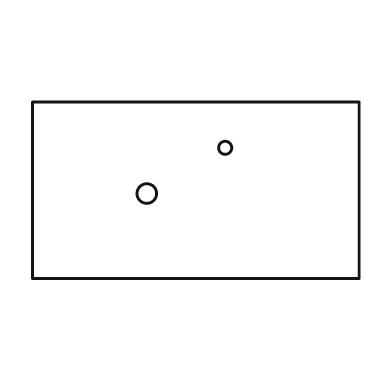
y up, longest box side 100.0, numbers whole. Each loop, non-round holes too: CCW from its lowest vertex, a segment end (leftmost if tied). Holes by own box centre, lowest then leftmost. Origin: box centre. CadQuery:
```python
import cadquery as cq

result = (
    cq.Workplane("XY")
    .moveTo(-50.0, -27.0)
    .lineTo(50.0, -27.0)
    .lineTo(50.0, 27.0)
    .lineTo(-50.0, 27.0)
    .close()
    .moveTo(-15.0, -1.0)
    .circle(3.0)
    .moveTo(9.0, 13.0)
    .circle(2.0)
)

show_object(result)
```